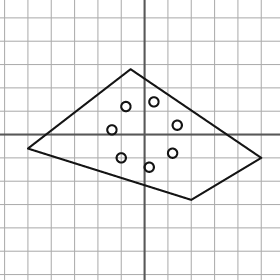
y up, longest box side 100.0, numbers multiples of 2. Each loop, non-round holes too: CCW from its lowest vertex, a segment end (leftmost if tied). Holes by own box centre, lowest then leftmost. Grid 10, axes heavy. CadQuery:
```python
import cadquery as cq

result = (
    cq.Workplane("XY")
    .moveTo(20.0, -28.0)
    .lineTo(50.0, -10.0)
    .lineTo(-6.0, 28.0)
    .lineTo(-50.0, -6.0)
    .close()
    .moveTo(2.0, -14.0)
    .circle(2.0)
    .moveTo(-10.0, -10.0)
    .circle(2.0)
    .moveTo(12.0, -8.0)
    .circle(2.0)
    .moveTo(-14.0, 2.0)
    .circle(2.0)
    .moveTo(14.0, 4.0)
    .circle(2.0)
    .moveTo(-8.0, 12.0)
    .circle(2.0)
    .moveTo(4.0, 14.0)
    .circle(2.0)
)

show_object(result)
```